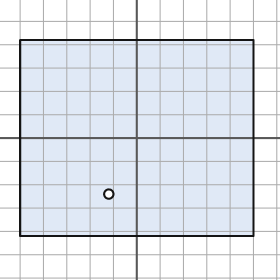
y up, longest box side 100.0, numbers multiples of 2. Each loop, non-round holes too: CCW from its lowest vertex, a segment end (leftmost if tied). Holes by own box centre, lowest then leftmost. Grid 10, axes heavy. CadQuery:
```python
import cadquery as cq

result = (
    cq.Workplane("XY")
    .moveTo(-50.0, -42.0)
    .lineTo(50.0, -42.0)
    .lineTo(50.0, 42.0)
    .lineTo(-50.0, 42.0)
    .close()
    .moveTo(-12.0, -24.0)
    .circle(2.0)
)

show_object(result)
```